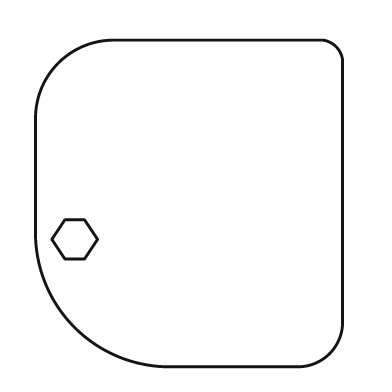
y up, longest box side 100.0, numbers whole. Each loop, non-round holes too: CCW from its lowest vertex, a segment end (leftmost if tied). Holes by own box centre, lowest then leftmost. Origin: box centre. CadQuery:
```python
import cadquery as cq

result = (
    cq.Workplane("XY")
    .moveTo(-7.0, -50.0)
    .lineTo(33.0, -50.0)
    .threePointArc((43.0, -46.0), (47.0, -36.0))
    .lineTo(47.0, 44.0)
    .threePointArc((45.0, 48.0), (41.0, 50.0))
    .lineTo(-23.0, 50.0)
    .threePointArc((-40.0, 43.0), (-47.0, 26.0))
    .lineTo(-47.0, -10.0)
    .threePointArc((-35.0, -38.0), (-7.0, -50.0))
    .close()
    .moveTo(-38.0, -17.0)
    .lineTo(-32.0, -17.0)
    .lineTo(-28.0, -11.0)
    .lineTo(-32.0, -5.0)
    .lineTo(-38.0, -5.0)
    .lineTo(-42.0, -11.0)
    .close()
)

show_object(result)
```